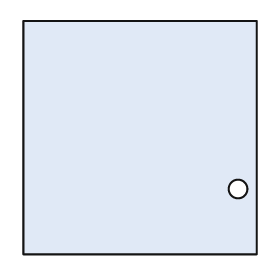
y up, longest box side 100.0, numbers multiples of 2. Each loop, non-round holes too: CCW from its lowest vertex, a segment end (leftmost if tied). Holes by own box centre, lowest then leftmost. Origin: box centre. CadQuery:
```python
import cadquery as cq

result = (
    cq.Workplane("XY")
    .moveTo(-50.0, -50.0)
    .lineTo(50.0, -50.0)
    .lineTo(50.0, 50.0)
    .lineTo(-50.0, 50.0)
    .close()
    .moveTo(42.0, -22.0)
    .circle(4.0)
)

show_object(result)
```